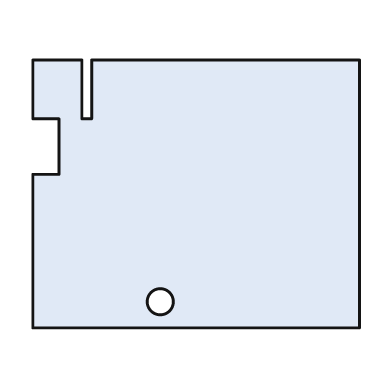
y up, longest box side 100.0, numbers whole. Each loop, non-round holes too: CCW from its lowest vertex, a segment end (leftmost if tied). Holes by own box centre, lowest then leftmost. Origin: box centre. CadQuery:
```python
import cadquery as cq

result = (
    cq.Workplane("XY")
    .moveTo(-50.0, -41.0)
    .lineTo(50.0, -41.0)
    .lineTo(50.0, 41.0)
    .lineTo(-32.0, 41.0)
    .lineTo(-32.0, 23.0)
    .lineTo(-35.0, 23.0)
    .lineTo(-35.0, 41.0)
    .lineTo(-50.0, 41.0)
    .lineTo(-50.0, 23.0)
    .lineTo(-42.0, 23.0)
    .lineTo(-42.0, 6.0)
    .lineTo(-50.0, 6.0)
    .close()
    .moveTo(-11.0, -33.0)
    .circle(4.0)
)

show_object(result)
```